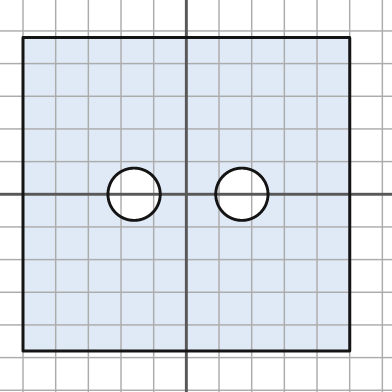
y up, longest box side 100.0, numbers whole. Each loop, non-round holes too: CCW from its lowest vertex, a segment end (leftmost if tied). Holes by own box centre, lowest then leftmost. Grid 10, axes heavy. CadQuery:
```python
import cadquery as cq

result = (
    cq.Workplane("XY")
    .moveTo(-50.0, -48.0)
    .lineTo(50.0, -48.0)
    .lineTo(50.0, 48.0)
    .lineTo(-50.0, 48.0)
    .close()
    .moveTo(-16.0, 0.0)
    .circle(8.0)
    .moveTo(17.0, 0.0)
    .circle(8.0)
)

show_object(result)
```